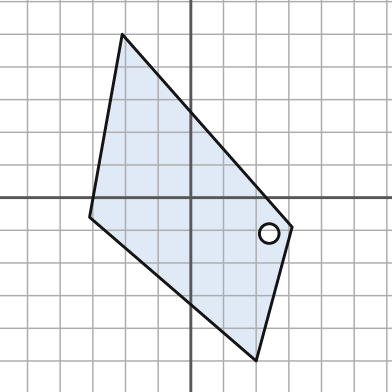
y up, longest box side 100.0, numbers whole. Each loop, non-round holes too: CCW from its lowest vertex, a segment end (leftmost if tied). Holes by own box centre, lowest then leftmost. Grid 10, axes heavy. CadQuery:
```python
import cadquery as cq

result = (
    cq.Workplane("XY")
    .moveTo(20.0, -50.0)
    .lineTo(31.0, -9.0)
    .lineTo(-21.0, 50.0)
    .lineTo(-31.0, -6.0)
    .close()
    .moveTo(24.0, -11.0)
    .circle(3.0)
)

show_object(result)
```